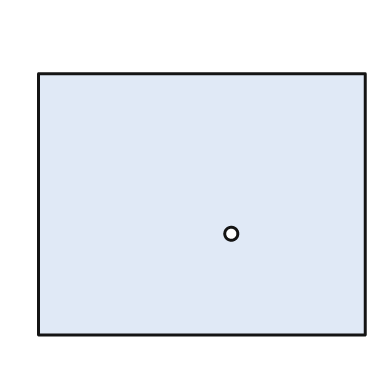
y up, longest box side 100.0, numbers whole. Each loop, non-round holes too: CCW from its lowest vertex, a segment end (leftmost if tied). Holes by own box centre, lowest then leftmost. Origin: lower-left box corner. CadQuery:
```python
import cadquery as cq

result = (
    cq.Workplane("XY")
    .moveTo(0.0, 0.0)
    .lineTo(100.0, 0.0)
    .lineTo(100.0, 80.0)
    .lineTo(0.0, 80.0)
    .close()
    .moveTo(59.0, 31.0)
    .circle(2.0)
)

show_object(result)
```